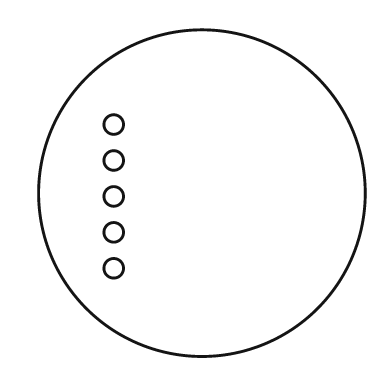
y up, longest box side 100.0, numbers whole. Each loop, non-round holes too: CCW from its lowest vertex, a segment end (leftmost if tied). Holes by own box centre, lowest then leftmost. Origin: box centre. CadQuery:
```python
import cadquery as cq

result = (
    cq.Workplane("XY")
    .moveTo(0.0, 0.0)
    .circle(50.0)
    .moveTo(-27.0, -23.0)
    .circle(3.0)
    .moveTo(-27.0, -12.0)
    .circle(3.0)
    .moveTo(-27.0, -1.0)
    .circle(3.0)
    .moveTo(-27.0, 10.0)
    .circle(3.0)
    .moveTo(-27.0, 21.0)
    .circle(3.0)
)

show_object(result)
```